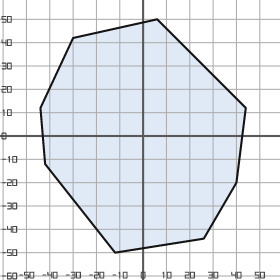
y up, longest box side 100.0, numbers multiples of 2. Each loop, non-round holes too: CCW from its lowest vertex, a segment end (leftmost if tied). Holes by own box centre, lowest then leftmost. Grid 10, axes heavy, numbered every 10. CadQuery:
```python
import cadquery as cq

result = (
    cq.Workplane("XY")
    .moveTo(-12.0, -50.0)
    .lineTo(26.0, -44.0)
    .lineTo(40.0, -20.0)
    .lineTo(44.0, 12.0)
    .lineTo(6.0, 50.0)
    .lineTo(-30.0, 42.0)
    .lineTo(-44.0, 12.0)
    .lineTo(-42.0, -12.0)
    .close()
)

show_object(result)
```